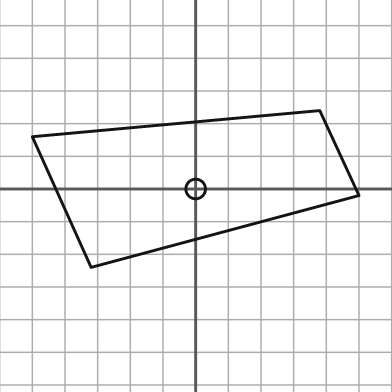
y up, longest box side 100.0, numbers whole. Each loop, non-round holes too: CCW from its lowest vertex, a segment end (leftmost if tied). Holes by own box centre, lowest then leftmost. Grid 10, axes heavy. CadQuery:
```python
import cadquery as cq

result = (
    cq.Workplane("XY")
    .moveTo(-32.0, -24.0)
    .lineTo(50.0, -2.0)
    .lineTo(38.0, 24.0)
    .lineTo(-50.0, 16.0)
    .close()
    .moveTo(0.0, 0.0)
    .circle(3.0)
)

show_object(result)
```